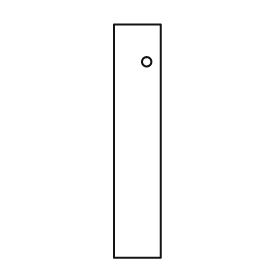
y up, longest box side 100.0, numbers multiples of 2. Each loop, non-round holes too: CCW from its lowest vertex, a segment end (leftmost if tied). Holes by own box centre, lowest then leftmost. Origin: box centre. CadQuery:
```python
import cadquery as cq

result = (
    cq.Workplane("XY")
    .moveTo(-10.0, -50.0)
    .lineTo(10.0, -50.0)
    .lineTo(10.0, 50.0)
    .lineTo(-10.0, 50.0)
    .close()
    .moveTo(4.0, 34.0)
    .circle(2.0)
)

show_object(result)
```